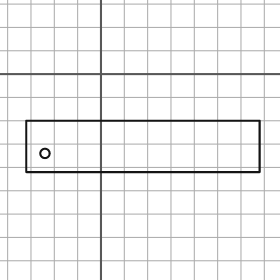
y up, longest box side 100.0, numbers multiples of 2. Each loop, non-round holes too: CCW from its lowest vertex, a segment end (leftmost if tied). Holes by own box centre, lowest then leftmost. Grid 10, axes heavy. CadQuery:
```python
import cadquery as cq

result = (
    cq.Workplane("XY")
    .moveTo(-32.0, -42.0)
    .lineTo(68.0, -42.0)
    .lineTo(68.0, -20.0)
    .lineTo(-32.0, -20.0)
    .close()
    .moveTo(-24.0, -34.0)
    .circle(2.0)
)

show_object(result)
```